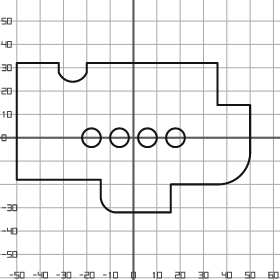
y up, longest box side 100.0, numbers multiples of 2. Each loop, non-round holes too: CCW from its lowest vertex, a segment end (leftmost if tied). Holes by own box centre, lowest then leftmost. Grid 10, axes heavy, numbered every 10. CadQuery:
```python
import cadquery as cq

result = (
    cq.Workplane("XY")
    .moveTo(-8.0, -32.0)
    .lineTo(16.0, -32.0)
    .lineTo(16.0, -20.0)
    .lineTo(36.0, -20.0)
    .threePointArc((46.0, -16.0), (50.0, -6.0))
    .lineTo(50.0, 14.0)
    .lineTo(36.0, 14.0)
    .lineTo(36.0, 32.0)
    .lineTo(-20.0, 32.0)
    .lineTo(-20.0, 28.0)
    .threePointArc((-26.0, 24.0), (-32.0, 28.0))
    .lineTo(-32.0, 32.0)
    .lineTo(-50.0, 32.0)
    .lineTo(-50.0, -18.0)
    .lineTo(-14.0, -18.0)
    .lineTo(-14.0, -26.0)
    .threePointArc((-12.0, -30.0), (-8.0, -32.0))
    .close()
    .moveTo(-18.0, 0.0)
    .circle(4.0)
    .moveTo(-6.0, 0.0)
    .circle(4.0)
    .moveTo(6.0, 0.0)
    .circle(4.0)
    .moveTo(18.0, 0.0)
    .circle(4.0)
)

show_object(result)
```